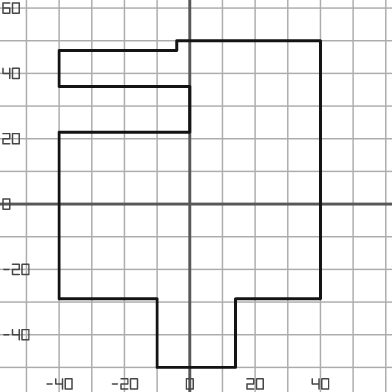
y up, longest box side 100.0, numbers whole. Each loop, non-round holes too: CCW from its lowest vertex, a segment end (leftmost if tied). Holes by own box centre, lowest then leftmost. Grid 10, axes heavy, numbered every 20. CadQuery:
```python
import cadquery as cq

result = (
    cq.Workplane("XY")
    .moveTo(-10.0, -50.0)
    .lineTo(14.0, -50.0)
    .lineTo(14.0, -29.0)
    .lineTo(40.0, -29.0)
    .lineTo(40.0, 50.0)
    .lineTo(-4.0, 50.0)
    .lineTo(-4.0, 47.0)
    .lineTo(-40.0, 47.0)
    .lineTo(-40.0, 36.0)
    .lineTo(0.0, 36.0)
    .lineTo(0.0, 22.0)
    .lineTo(-40.0, 22.0)
    .lineTo(-40.0, -29.0)
    .lineTo(-10.0, -29.0)
    .close()
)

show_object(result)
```